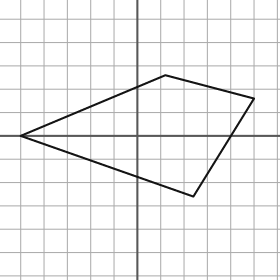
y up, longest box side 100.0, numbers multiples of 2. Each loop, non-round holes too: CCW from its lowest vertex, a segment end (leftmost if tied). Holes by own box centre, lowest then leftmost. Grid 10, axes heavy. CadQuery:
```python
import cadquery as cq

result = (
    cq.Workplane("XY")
    .moveTo(24.0, -26.0)
    .lineTo(50.0, 16.0)
    .lineTo(12.0, 26.0)
    .lineTo(-50.0, 0.0)
    .close()
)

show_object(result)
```